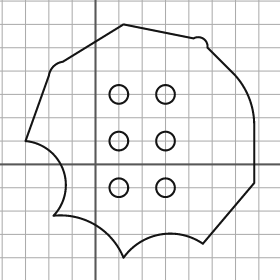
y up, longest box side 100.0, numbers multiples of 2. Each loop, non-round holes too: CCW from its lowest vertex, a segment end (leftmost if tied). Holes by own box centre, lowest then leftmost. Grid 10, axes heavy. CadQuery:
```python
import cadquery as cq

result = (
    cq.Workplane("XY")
    .moveTo(12.0, -40.0)
    .threePointArc((28.0, -30.0), (46.0, -34.0))
    .lineTo(68.0, -8.0)
    .lineTo(68.0, 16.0)
    .threePointArc((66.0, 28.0), (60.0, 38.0))
    .lineTo(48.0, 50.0)
    .threePointArc((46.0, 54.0), (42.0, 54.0))
    .lineTo(12.0, 60.0)
    .lineTo(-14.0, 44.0)
    .threePointArc((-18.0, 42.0), (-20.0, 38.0))
    .lineTo(-30.0, 10.0)
    .threePointArc((-14.0, -2.0), (-18.0, -22.0))
    .threePointArc((0.0, -26.0), (12.0, -40.0))
    .close()
    .moveTo(10.0, -10.0)
    .circle(4.0)
    .moveTo(30.0, -10.0)
    .circle(4.0)
    .moveTo(10.0, 10.0)
    .circle(4.0)
    .moveTo(30.0, 10.0)
    .circle(4.0)
    .moveTo(10.0, 30.0)
    .circle(4.0)
    .moveTo(30.0, 30.0)
    .circle(4.0)
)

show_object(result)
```